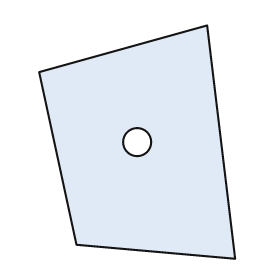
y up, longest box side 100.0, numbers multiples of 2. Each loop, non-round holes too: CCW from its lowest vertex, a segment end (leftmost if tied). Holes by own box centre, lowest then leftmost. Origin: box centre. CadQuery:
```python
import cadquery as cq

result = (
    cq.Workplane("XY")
    .moveTo(42.0, -50.0)
    .lineTo(30.0, 50.0)
    .lineTo(-42.0, 30.0)
    .lineTo(-26.0, -44.0)
    .close()
    .moveTo(0.0, 0.0)
    .circle(6.0)
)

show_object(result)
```